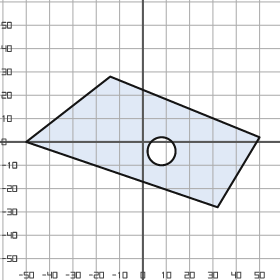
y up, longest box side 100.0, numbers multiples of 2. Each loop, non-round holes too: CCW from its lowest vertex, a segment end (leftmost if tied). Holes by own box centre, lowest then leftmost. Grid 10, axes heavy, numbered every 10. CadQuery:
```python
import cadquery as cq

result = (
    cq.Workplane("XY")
    .moveTo(32.0, -28.0)
    .lineTo(50.0, 2.0)
    .lineTo(-14.0, 28.0)
    .lineTo(-50.0, 0.0)
    .close()
    .moveTo(8.0, -4.0)
    .circle(6.0)
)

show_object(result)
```